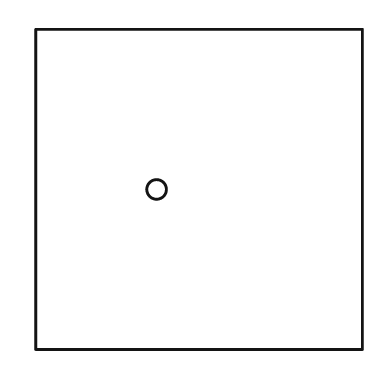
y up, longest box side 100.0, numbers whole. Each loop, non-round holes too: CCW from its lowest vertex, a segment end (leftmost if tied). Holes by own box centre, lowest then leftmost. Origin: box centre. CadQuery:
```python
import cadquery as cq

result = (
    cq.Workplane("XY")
    .moveTo(-50.0, -49.0)
    .lineTo(50.0, -49.0)
    .lineTo(50.0, 49.0)
    .lineTo(-50.0, 49.0)
    .close()
    .moveTo(-13.0, 0.0)
    .circle(3.0)
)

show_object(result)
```